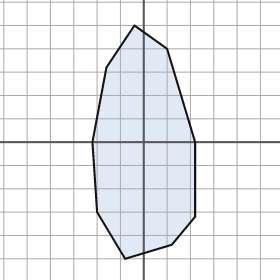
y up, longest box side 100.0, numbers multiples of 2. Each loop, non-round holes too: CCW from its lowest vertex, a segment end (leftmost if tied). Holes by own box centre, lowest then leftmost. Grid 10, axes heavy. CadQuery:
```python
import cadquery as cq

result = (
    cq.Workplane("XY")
    .moveTo(-8.0, -50.0)
    .lineTo(12.0, -44.0)
    .lineTo(22.0, -32.0)
    .lineTo(22.0, 0.0)
    .lineTo(10.0, 40.0)
    .lineTo(-4.0, 50.0)
    .lineTo(-16.0, 32.0)
    .lineTo(-22.0, 0.0)
    .lineTo(-20.0, -30.0)
    .close()
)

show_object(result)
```